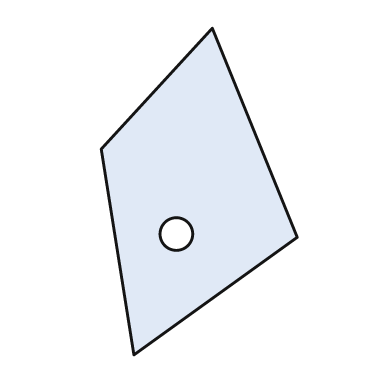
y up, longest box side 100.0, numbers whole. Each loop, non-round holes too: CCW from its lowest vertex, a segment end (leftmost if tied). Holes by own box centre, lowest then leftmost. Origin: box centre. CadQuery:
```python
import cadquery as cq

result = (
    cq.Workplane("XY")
    .moveTo(-20.0, -50.0)
    .lineTo(30.0, -14.0)
    .lineTo(4.0, 50.0)
    .lineTo(-30.0, 13.0)
    .close()
    .moveTo(-7.0, -13.0)
    .circle(5.0)
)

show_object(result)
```